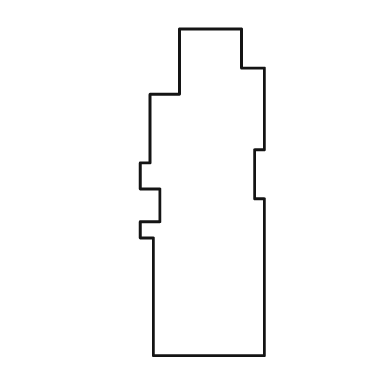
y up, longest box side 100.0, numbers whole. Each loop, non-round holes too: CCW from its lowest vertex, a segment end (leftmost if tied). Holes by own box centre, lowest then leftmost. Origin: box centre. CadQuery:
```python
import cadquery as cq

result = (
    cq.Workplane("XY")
    .moveTo(-15.0, -50.0)
    .lineTo(19.0, -50.0)
    .lineTo(19.0, -2.0)
    .lineTo(16.0, -2.0)
    .lineTo(16.0, 13.0)
    .lineTo(19.0, 13.0)
    .lineTo(19.0, 38.0)
    .lineTo(12.0, 38.0)
    .lineTo(12.0, 50.0)
    .lineTo(-7.0, 50.0)
    .lineTo(-7.0, 30.0)
    .lineTo(-16.0, 30.0)
    .lineTo(-16.0, 9.0)
    .lineTo(-19.0, 9.0)
    .lineTo(-19.0, 1.0)
    .lineTo(-13.0, 1.0)
    .lineTo(-13.0, -9.0)
    .lineTo(-19.0, -9.0)
    .lineTo(-19.0, -14.0)
    .lineTo(-15.0, -14.0)
    .close()
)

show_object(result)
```